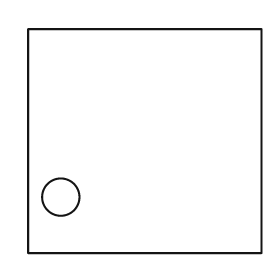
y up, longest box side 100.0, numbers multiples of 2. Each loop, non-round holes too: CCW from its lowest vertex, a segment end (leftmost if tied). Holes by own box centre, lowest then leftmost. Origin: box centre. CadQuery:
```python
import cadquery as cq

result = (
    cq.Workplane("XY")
    .moveTo(-50.0, -48.0)
    .lineTo(50.0, -48.0)
    .lineTo(50.0, 48.0)
    .lineTo(-50.0, 48.0)
    .close()
    .moveTo(-36.0, -24.0)
    .circle(8.0)
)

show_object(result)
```